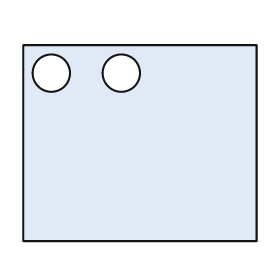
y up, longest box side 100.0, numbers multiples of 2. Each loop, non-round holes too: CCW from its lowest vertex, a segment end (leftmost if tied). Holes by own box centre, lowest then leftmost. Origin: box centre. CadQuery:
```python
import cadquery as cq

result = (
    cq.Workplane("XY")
    .moveTo(-50.0, -42.0)
    .lineTo(50.0, -42.0)
    .lineTo(50.0, 42.0)
    .lineTo(-50.0, 42.0)
    .close()
    .moveTo(-38.0, 30.0)
    .circle(8.0)
    .moveTo(-8.0, 30.0)
    .circle(8.0)
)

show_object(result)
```